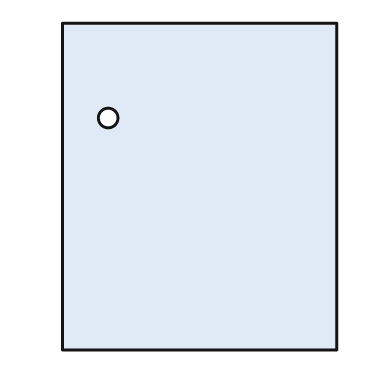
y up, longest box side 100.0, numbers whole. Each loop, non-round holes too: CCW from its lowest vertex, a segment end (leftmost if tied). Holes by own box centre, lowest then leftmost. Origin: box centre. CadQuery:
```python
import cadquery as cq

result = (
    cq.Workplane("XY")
    .moveTo(-42.0, -50.0)
    .lineTo(42.0, -50.0)
    .lineTo(42.0, 50.0)
    .lineTo(-42.0, 50.0)
    .close()
    .moveTo(-28.0, 21.0)
    .circle(3.0)
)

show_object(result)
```